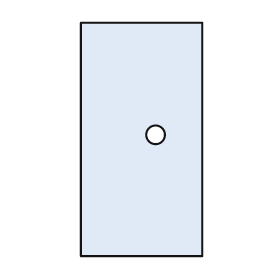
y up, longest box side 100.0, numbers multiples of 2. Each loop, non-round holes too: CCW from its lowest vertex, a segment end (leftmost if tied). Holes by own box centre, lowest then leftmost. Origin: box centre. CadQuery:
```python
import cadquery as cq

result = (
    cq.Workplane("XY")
    .moveTo(-26.0, -50.0)
    .lineTo(26.0, -50.0)
    .lineTo(26.0, 50.0)
    .lineTo(-26.0, 50.0)
    .close()
    .moveTo(6.0, 2.0)
    .circle(4.0)
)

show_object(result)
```